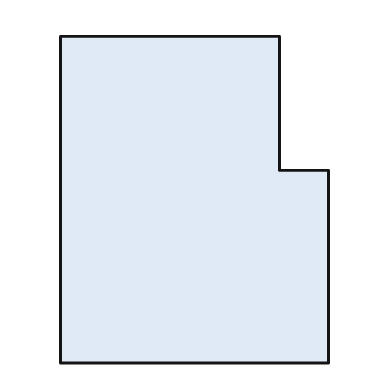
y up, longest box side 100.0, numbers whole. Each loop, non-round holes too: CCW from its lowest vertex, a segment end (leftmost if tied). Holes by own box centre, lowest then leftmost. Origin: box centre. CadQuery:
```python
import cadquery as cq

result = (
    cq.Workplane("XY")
    .moveTo(-41.0, -50.0)
    .lineTo(41.0, -50.0)
    .lineTo(41.0, 9.0)
    .lineTo(26.0, 9.0)
    .lineTo(26.0, 50.0)
    .lineTo(-41.0, 50.0)
    .close()
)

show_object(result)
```